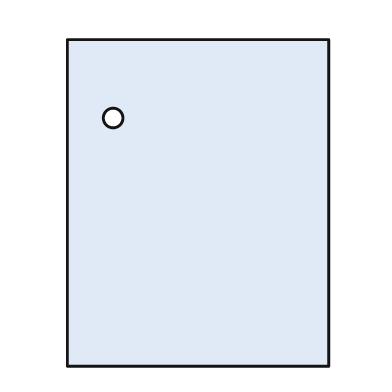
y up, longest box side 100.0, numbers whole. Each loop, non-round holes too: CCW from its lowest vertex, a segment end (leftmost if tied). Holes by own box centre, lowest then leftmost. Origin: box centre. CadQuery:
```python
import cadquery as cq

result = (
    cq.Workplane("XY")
    .moveTo(-40.0, -50.0)
    .lineTo(40.0, -50.0)
    .lineTo(40.0, 50.0)
    .lineTo(-40.0, 50.0)
    .close()
    .moveTo(-26.0, 26.0)
    .circle(3.0)
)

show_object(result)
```